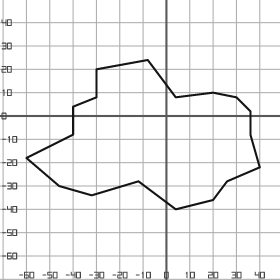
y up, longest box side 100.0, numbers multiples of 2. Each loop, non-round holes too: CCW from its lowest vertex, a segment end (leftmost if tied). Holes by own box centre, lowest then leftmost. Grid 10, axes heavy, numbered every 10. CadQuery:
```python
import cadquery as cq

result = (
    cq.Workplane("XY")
    .moveTo(4.0, -40.0)
    .lineTo(20.0, -36.0)
    .lineTo(26.0, -28.0)
    .lineTo(40.0, -22.0)
    .lineTo(36.0, -8.0)
    .lineTo(36.0, 2.0)
    .lineTo(30.0, 8.0)
    .lineTo(20.0, 10.0)
    .lineTo(4.0, 8.0)
    .lineTo(-8.0, 24.0)
    .lineTo(-30.0, 20.0)
    .lineTo(-30.0, 8.0)
    .lineTo(-40.0, 4.0)
    .lineTo(-40.0, -8.0)
    .lineTo(-60.0, -18.0)
    .lineTo(-46.0, -30.0)
    .lineTo(-32.0, -34.0)
    .lineTo(-12.0, -28.0)
    .close()
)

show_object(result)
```